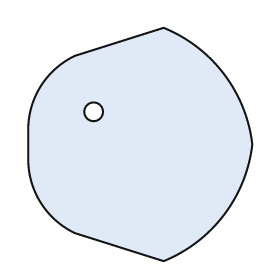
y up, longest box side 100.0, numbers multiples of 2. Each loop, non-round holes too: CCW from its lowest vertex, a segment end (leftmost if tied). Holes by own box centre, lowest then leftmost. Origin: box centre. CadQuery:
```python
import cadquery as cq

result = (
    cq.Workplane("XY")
    .moveTo(10.0, -50.0)
    .threePointArc((36.0, -30.0), (48.0, 0.0))
    .threePointArc((36.0, 30.0), (10.0, 50.0))
    .lineTo(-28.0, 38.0)
    .threePointArc((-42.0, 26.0), (-48.0, 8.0))
    .lineTo(-48.0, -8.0)
    .threePointArc((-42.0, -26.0), (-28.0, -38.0))
    .close()
    .moveTo(-20.0, 14.0)
    .circle(4.0)
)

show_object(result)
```